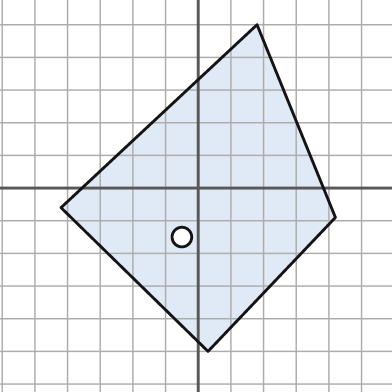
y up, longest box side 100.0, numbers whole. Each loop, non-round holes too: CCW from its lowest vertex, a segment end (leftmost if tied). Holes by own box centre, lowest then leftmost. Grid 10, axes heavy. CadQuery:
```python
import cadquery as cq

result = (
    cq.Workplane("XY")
    .moveTo(3.0, -50.0)
    .lineTo(42.0, -9.0)
    .lineTo(18.0, 50.0)
    .lineTo(-42.0, -6.0)
    .close()
    .moveTo(-5.0, -15.0)
    .circle(3.0)
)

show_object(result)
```